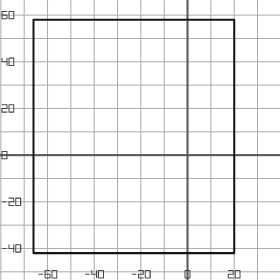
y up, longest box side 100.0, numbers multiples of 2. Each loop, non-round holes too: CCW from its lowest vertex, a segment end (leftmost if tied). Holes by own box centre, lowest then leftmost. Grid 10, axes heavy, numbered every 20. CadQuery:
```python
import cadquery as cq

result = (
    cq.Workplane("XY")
    .moveTo(-66.0, -42.0)
    .lineTo(20.0, -42.0)
    .lineTo(20.0, 58.0)
    .lineTo(-66.0, 58.0)
    .close()
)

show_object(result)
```